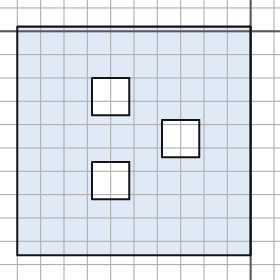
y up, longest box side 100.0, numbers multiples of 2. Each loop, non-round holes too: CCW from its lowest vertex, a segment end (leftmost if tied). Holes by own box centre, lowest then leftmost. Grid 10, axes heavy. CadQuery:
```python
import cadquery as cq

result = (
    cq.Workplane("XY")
    .moveTo(-100.0, -96.0)
    .lineTo(0.0, -96.0)
    .lineTo(0.0, 2.0)
    .lineTo(-100.0, 2.0)
    .close()
    .moveTo(-68.0, -72.0)
    .lineTo(-52.0, -72.0)
    .lineTo(-52.0, -56.0)
    .lineTo(-68.0, -56.0)
    .close()
    .moveTo(-38.0, -54.0)
    .lineTo(-22.0, -54.0)
    .lineTo(-22.0, -38.0)
    .lineTo(-38.0, -38.0)
    .close()
    .moveTo(-68.0, -36.0)
    .lineTo(-52.0, -36.0)
    .lineTo(-52.0, -20.0)
    .lineTo(-68.0, -20.0)
    .close()
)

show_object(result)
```